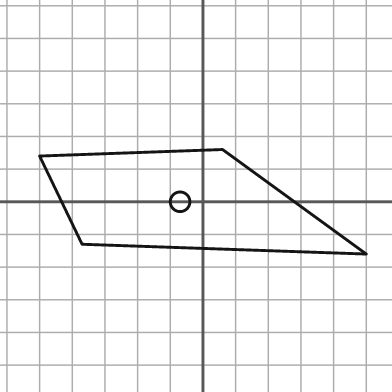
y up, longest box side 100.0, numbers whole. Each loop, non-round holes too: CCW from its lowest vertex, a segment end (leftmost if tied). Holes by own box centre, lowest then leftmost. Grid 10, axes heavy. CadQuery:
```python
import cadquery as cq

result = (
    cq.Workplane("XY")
    .moveTo(50.0, -16.0)
    .lineTo(6.0, 16.0)
    .lineTo(-50.0, 14.0)
    .lineTo(-37.0, -13.0)
    .close()
    .moveTo(-7.0, 0.0)
    .circle(3.0)
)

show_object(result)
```